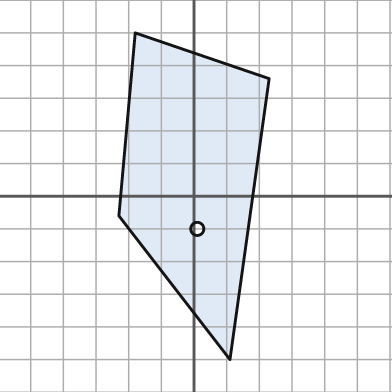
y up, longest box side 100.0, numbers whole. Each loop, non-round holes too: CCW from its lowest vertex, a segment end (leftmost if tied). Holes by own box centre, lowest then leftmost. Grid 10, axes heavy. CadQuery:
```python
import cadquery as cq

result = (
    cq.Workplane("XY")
    .moveTo(11.0, -50.0)
    .lineTo(23.0, 36.0)
    .lineTo(-18.0, 50.0)
    .lineTo(-23.0, -6.0)
    .close()
    .moveTo(1.0, -10.0)
    .circle(2.0)
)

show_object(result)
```